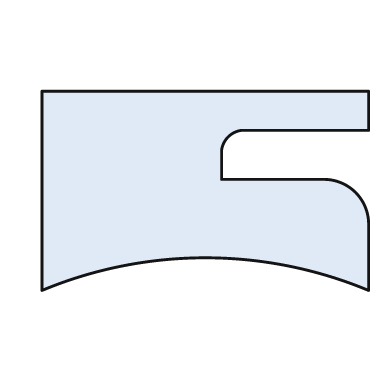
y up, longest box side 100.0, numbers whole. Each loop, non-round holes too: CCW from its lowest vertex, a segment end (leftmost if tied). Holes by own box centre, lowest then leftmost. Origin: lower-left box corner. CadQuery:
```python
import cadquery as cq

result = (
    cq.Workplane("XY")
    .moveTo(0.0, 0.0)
    .threePointArc((50.0, 10.0), (100.0, 0.0))
    .lineTo(100.0, 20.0)
    .threePointArc((96.0, 30.0), (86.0, 34.0))
    .lineTo(55.0, 34.0)
    .lineTo(55.0, 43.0)
    .threePointArc((57.0, 47.0), (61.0, 49.0))
    .lineTo(100.0, 49.0)
    .lineTo(100.0, 61.0)
    .lineTo(0.0, 61.0)
    .close()
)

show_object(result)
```